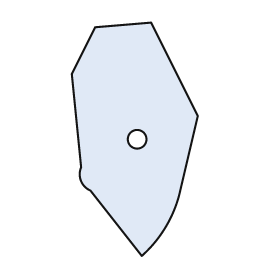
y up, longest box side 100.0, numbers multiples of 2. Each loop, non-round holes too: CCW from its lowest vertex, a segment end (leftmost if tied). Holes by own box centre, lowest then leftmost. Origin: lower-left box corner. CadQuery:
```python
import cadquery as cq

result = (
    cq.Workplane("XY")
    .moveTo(30.0, 0.0)
    .threePointArc((40.0, 12.0), (46.0, 26.0))
    .lineTo(54.0, 60.0)
    .lineTo(34.0, 100.0)
    .lineTo(10.0, 98.0)
    .lineTo(0.0, 78.0)
    .lineTo(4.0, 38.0)
    .threePointArc((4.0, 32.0), (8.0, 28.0))
    .close()
    .moveTo(28.0, 50.0)
    .circle(4.0)
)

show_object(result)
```